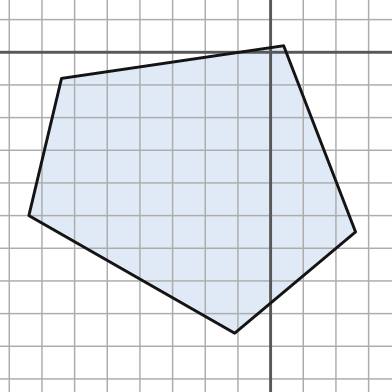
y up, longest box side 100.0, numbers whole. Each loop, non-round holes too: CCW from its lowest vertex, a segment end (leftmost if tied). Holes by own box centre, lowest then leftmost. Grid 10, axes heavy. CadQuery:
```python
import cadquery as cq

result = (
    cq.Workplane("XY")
    .moveTo(-11.0, -86.0)
    .lineTo(26.0, -55.0)
    .lineTo(4.0, 2.0)
    .lineTo(-64.0, -8.0)
    .lineTo(-74.0, -50.0)
    .close()
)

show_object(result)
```